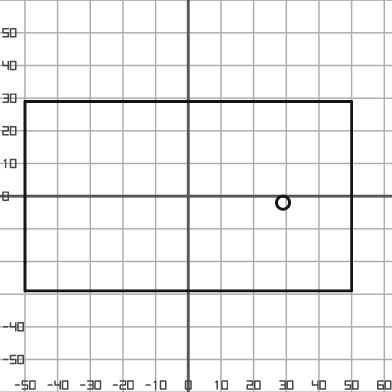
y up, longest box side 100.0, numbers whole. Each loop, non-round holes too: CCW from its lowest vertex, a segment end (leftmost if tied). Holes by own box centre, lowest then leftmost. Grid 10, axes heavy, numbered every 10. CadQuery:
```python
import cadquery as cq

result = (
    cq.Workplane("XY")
    .moveTo(-50.0, -29.0)
    .lineTo(50.0, -29.0)
    .lineTo(50.0, 29.0)
    .lineTo(-50.0, 29.0)
    .close()
    .moveTo(29.0, -2.0)
    .circle(2.0)
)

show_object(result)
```